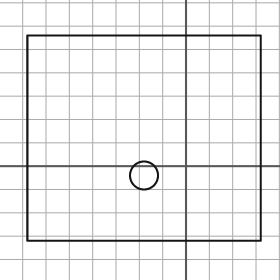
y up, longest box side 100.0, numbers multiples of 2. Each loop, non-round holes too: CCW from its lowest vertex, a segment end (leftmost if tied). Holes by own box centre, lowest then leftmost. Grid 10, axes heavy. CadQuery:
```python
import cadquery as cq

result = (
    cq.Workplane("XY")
    .moveTo(-68.0, -32.0)
    .lineTo(32.0, -32.0)
    .lineTo(32.0, 56.0)
    .lineTo(-68.0, 56.0)
    .close()
    .moveTo(-18.0, -4.0)
    .circle(6.0)
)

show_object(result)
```